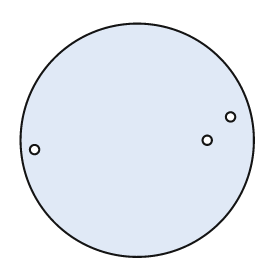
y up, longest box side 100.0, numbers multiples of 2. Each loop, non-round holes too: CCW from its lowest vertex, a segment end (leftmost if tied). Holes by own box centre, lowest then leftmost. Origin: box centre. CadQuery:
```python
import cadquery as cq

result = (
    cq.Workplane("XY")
    .moveTo(0.0, 0.0)
    .circle(50.0)
    .moveTo(-44.0, -4.0)
    .circle(2.0)
    .moveTo(30.0, 0.0)
    .circle(2.0)
    .moveTo(40.0, 10.0)
    .circle(2.0)
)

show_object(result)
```